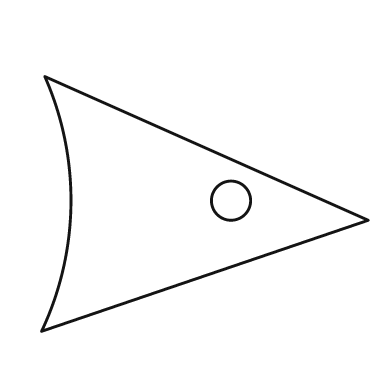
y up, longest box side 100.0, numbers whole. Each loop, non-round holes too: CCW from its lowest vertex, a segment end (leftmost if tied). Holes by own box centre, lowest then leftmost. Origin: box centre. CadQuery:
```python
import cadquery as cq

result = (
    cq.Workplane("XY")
    .moveTo(-50.0, -39.0)
    .lineTo(50.0, -5.0)
    .lineTo(-49.0, 39.0)
    .threePointArc((-41.0, 0.0), (-50.0, -39.0))
    .close()
    .moveTo(8.0, 1.0)
    .circle(6.0)
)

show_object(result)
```